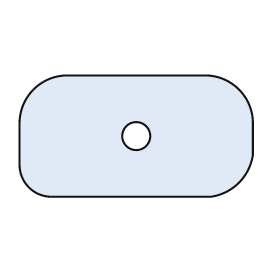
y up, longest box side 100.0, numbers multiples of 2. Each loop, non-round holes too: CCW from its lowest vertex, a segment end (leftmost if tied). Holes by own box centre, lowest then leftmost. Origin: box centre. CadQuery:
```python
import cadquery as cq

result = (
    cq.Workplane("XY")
    .moveTo(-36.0, -26.0)
    .lineTo(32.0, -26.0)
    .threePointArc((44.0, -20.0), (50.0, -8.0))
    .lineTo(50.0, 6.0)
    .threePointArc((44.0, 20.0), (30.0, 26.0))
    .lineTo(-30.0, 26.0)
    .threePointArc((-44.0, 20.0), (-50.0, 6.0))
    .lineTo(-50.0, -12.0)
    .threePointArc((-46.0, -22.0), (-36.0, -26.0))
    .close()
    .moveTo(0.0, 0.0)
    .circle(6.0)
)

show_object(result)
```